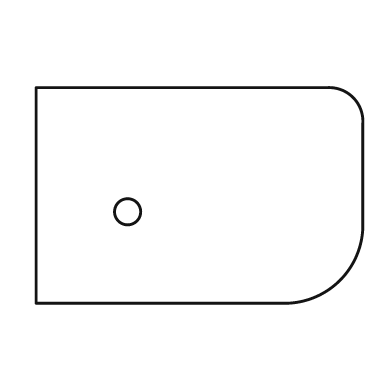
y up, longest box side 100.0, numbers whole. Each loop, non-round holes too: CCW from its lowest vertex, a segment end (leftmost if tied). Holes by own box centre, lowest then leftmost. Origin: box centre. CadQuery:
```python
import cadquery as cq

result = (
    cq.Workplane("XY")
    .moveTo(-50.0, -33.0)
    .lineTo(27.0, -33.0)
    .threePointArc((43.0, -26.0), (50.0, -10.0))
    .lineTo(50.0, 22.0)
    .threePointArc((47.0, 30.0), (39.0, 33.0))
    .lineTo(-50.0, 33.0)
    .close()
    .moveTo(-22.0, -5.0)
    .circle(4.0)
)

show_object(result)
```